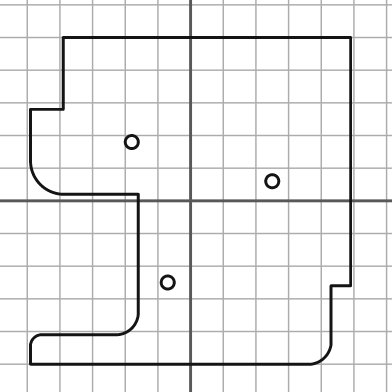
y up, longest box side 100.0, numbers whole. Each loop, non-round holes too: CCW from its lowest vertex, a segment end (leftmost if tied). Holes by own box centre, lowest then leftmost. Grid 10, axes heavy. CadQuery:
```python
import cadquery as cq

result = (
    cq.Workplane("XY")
    .moveTo(-49.0, -50.0)
    .lineTo(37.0, -50.0)
    .threePointArc((41.0, -48.0), (43.0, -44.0))
    .lineTo(43.0, -26.0)
    .lineTo(49.0, -26.0)
    .lineTo(49.0, 50.0)
    .lineTo(-39.0, 50.0)
    .lineTo(-39.0, 28.0)
    .lineTo(-49.0, 28.0)
    .lineTo(-49.0, 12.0)
    .threePointArc((-46.0, 5.0), (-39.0, 2.0))
    .lineTo(-16.0, 2.0)
    .lineTo(-16.0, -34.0)
    .threePointArc((-18.0, -39.0), (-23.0, -41.0))
    .lineTo(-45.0, -41.0)
    .threePointArc((-48.0, -42.0), (-49.0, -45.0))
    .close()
    .moveTo(-7.0, -25.0)
    .circle(2.0)
    .moveTo(25.0, 6.0)
    .circle(2.0)
    .moveTo(-18.0, 18.0)
    .circle(2.0)
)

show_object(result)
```